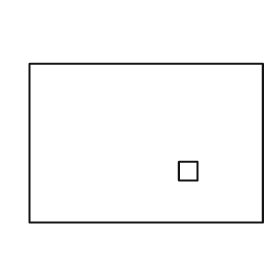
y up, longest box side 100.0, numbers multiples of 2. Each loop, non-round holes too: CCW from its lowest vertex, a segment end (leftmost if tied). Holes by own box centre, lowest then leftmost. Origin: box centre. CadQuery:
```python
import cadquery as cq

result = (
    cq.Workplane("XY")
    .moveTo(-50.0, -34.0)
    .lineTo(50.0, -34.0)
    .lineTo(50.0, 34.0)
    .lineTo(-50.0, 34.0)
    .close()
    .moveTo(14.0, -16.0)
    .lineTo(22.0, -16.0)
    .lineTo(22.0, -8.0)
    .lineTo(14.0, -8.0)
    .close()
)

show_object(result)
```